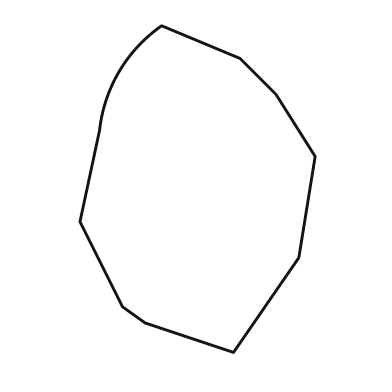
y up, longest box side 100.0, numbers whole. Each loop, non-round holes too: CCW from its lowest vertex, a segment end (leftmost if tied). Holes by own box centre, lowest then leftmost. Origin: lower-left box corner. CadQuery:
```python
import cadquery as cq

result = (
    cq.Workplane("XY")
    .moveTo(47.0, 0.0)
    .lineTo(67.0, 29.0)
    .lineTo(72.0, 60.0)
    .lineTo(60.0, 79.0)
    .lineTo(49.0, 90.0)
    .lineTo(25.0, 100.0)
    .threePointArc((12.0, 86.0), (6.0, 68.0))
    .lineTo(0.0, 40.0)
    .lineTo(13.0, 14.0)
    .lineTo(20.0, 9.0)
    .close()
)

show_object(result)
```